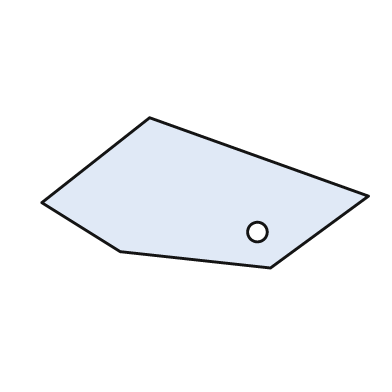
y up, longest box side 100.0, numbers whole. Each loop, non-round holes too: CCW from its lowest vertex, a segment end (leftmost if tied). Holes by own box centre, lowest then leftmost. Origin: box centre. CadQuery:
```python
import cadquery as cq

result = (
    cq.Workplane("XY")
    .moveTo(20.0, -23.0)
    .lineTo(50.0, -1.0)
    .lineTo(-17.0, 23.0)
    .lineTo(-50.0, -3.0)
    .lineTo(-26.0, -18.0)
    .close()
    .moveTo(16.0, -12.0)
    .circle(3.0)
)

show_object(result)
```